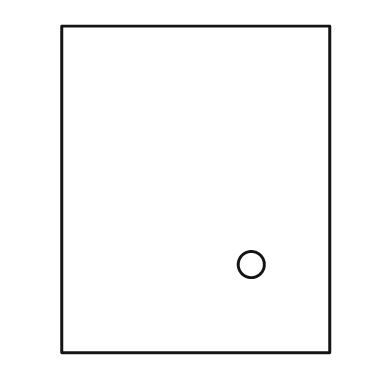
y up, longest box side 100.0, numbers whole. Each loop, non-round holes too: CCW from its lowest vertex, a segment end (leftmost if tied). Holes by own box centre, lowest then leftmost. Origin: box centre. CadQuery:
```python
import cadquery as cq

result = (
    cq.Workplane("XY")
    .moveTo(-41.0, -50.0)
    .lineTo(41.0, -50.0)
    .lineTo(41.0, 50.0)
    .lineTo(-41.0, 50.0)
    .close()
    .moveTo(17.0, -23.0)
    .circle(4.0)
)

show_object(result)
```